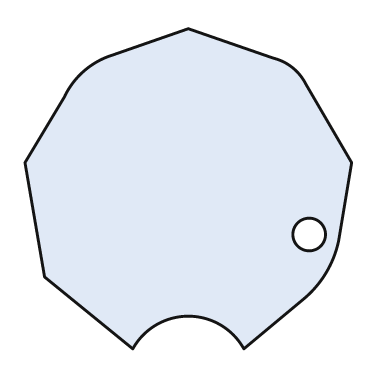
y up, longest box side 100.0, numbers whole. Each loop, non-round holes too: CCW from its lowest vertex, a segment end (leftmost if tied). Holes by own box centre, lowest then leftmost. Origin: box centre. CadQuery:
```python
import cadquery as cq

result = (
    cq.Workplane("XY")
    .moveTo(-17.0, -49.0)
    .threePointArc((0.0, -39.0), (17.0, -49.0))
    .lineTo(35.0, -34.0)
    .threePointArc((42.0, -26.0), (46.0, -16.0))
    .lineTo(50.0, 8.0)
    .lineTo(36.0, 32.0)
    .threePointArc((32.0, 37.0), (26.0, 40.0))
    .lineTo(0.0, 49.0)
    .lineTo(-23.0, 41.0)
    .threePointArc((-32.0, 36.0), (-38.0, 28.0))
    .lineTo(-50.0, 8.0)
    .lineTo(-44.0, -27.0)
    .close()
    .moveTo(37.0, -14.0)
    .circle(5.0)
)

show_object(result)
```